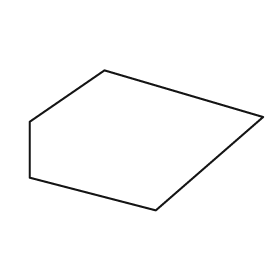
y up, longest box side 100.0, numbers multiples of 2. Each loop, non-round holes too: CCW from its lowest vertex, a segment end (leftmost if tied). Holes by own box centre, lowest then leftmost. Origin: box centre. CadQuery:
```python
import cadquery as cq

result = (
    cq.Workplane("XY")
    .moveTo(4.0, -30.0)
    .lineTo(50.0, 10.0)
    .lineTo(-18.0, 30.0)
    .lineTo(-50.0, 8.0)
    .lineTo(-50.0, -16.0)
    .close()
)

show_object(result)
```